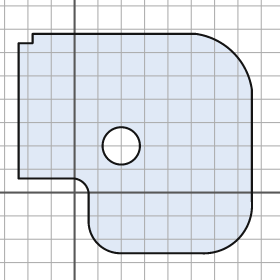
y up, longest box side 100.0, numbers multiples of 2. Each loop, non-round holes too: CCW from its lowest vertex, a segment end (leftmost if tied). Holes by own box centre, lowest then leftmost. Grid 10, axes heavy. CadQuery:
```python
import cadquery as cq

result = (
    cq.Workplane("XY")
    .moveTo(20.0, -26.0)
    .lineTo(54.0, -26.0)
    .threePointArc((70.0, -20.0), (76.0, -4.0))
    .lineTo(76.0, 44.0)
    .threePointArc((68.0, 60.0), (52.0, 68.0))
    .lineTo(-18.0, 68.0)
    .lineTo(-18.0, 64.0)
    .lineTo(-24.0, 64.0)
    .lineTo(-24.0, 6.0)
    .lineTo(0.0, 6.0)
    .threePointArc((4.0, 4.0), (6.0, 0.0))
    .lineTo(6.0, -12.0)
    .threePointArc((10.0, -22.0), (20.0, -26.0))
    .close()
    .moveTo(20.0, 20.0)
    .circle(8.0)
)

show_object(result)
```